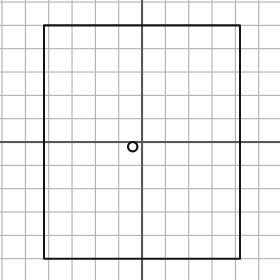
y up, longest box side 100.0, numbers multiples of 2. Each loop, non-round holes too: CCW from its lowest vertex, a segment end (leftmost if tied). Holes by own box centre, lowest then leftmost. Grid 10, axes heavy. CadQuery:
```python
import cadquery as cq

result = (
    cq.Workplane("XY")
    .moveTo(-42.0, -50.0)
    .lineTo(42.0, -50.0)
    .lineTo(42.0, 50.0)
    .lineTo(-42.0, 50.0)
    .close()
    .moveTo(-4.0, -2.0)
    .circle(2.0)
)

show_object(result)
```